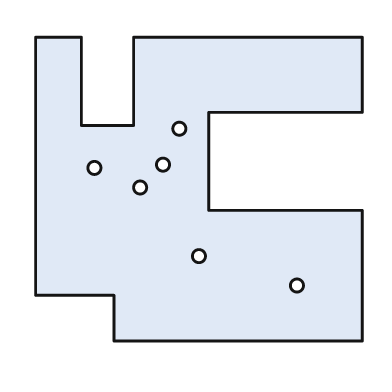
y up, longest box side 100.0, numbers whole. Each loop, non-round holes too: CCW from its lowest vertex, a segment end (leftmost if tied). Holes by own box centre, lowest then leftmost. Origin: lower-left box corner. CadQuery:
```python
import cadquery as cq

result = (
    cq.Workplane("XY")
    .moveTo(24.0, 0.0)
    .lineTo(100.0, 0.0)
    .lineTo(100.0, 40.0)
    .lineTo(53.0, 40.0)
    .lineTo(53.0, 70.0)
    .lineTo(100.0, 70.0)
    .lineTo(100.0, 93.0)
    .lineTo(30.0, 93.0)
    .lineTo(30.0, 66.0)
    .lineTo(14.0, 66.0)
    .lineTo(14.0, 93.0)
    .lineTo(0.0, 93.0)
    .lineTo(0.0, 14.0)
    .lineTo(24.0, 14.0)
    .close()
    .moveTo(80.0, 17.0)
    .circle(2.0)
    .moveTo(50.0, 26.0)
    .circle(2.0)
    .moveTo(32.0, 47.0)
    .circle(2.0)
    .moveTo(18.0, 53.0)
    .circle(2.0)
    .moveTo(39.0, 54.0)
    .circle(2.0)
    .moveTo(44.0, 65.0)
    .circle(2.0)
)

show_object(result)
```